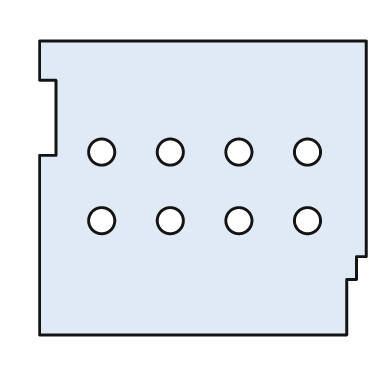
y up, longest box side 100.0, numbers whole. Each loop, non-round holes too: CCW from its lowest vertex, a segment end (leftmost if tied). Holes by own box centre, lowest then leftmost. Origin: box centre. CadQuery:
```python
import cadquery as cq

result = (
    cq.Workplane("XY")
    .moveTo(-50.0, -45.0)
    .lineTo(44.0, -45.0)
    .lineTo(44.0, -28.0)
    .lineTo(47.0, -28.0)
    .lineTo(47.0, -21.0)
    .lineTo(50.0, -21.0)
    .lineTo(50.0, 45.0)
    .lineTo(-50.0, 45.0)
    .lineTo(-50.0, 33.0)
    .lineTo(-45.0, 33.0)
    .lineTo(-45.0, 10.0)
    .lineTo(-50.0, 10.0)
    .close()
    .moveTo(-31.0, -10.0)
    .circle(4.0)
    .moveTo(-10.0, -10.0)
    .circle(4.0)
    .moveTo(11.0, -10.0)
    .circle(4.0)
    .moveTo(32.0, -10.0)
    .circle(4.0)
    .moveTo(-31.0, 11.0)
    .circle(4.0)
    .moveTo(-10.0, 11.0)
    .circle(4.0)
    .moveTo(11.0, 11.0)
    .circle(4.0)
    .moveTo(32.0, 11.0)
    .circle(4.0)
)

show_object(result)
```